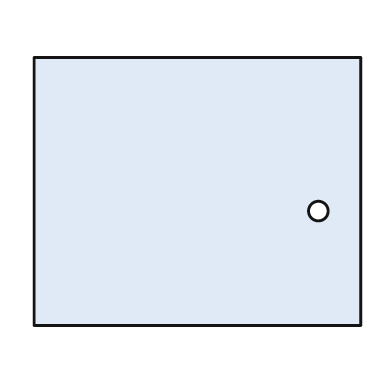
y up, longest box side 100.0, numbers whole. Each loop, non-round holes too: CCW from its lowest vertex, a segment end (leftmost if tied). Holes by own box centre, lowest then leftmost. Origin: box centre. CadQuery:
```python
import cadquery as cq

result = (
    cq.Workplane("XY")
    .moveTo(-50.0, -41.0)
    .lineTo(50.0, -41.0)
    .lineTo(50.0, 41.0)
    .lineTo(-50.0, 41.0)
    .close()
    .moveTo(37.0, -6.0)
    .circle(3.0)
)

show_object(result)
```